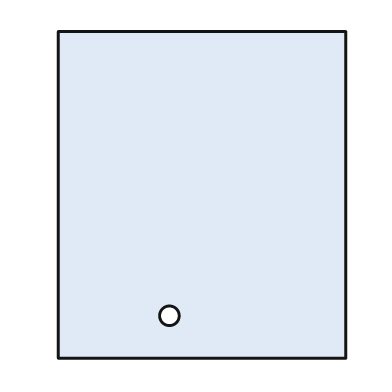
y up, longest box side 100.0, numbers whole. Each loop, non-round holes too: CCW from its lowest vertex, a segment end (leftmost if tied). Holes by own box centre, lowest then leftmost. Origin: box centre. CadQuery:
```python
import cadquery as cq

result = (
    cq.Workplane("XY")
    .moveTo(-44.0, -50.0)
    .lineTo(44.0, -50.0)
    .lineTo(44.0, 50.0)
    .lineTo(-44.0, 50.0)
    .close()
    .moveTo(-10.0, -37.0)
    .circle(3.0)
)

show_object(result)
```